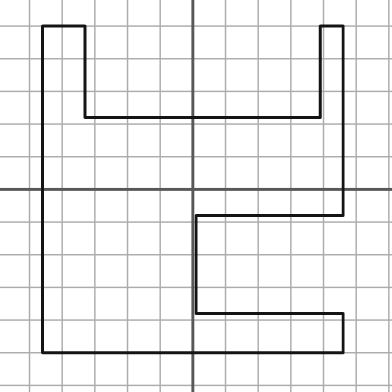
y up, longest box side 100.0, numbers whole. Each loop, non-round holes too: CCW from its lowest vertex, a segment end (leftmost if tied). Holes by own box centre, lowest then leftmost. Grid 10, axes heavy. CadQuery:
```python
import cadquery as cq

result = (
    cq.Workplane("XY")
    .moveTo(-46.0, -50.0)
    .lineTo(46.0, -50.0)
    .lineTo(46.0, -38.0)
    .lineTo(1.0, -38.0)
    .lineTo(1.0, -8.0)
    .lineTo(46.0, -8.0)
    .lineTo(46.0, 50.0)
    .lineTo(39.0, 50.0)
    .lineTo(39.0, 22.0)
    .lineTo(-33.0, 22.0)
    .lineTo(-33.0, 50.0)
    .lineTo(-46.0, 50.0)
    .close()
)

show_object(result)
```